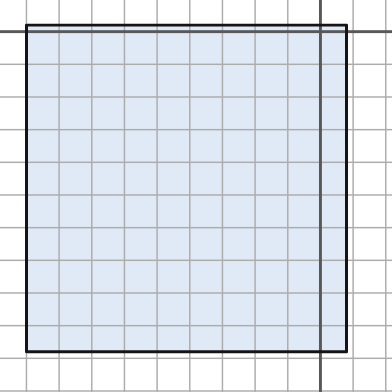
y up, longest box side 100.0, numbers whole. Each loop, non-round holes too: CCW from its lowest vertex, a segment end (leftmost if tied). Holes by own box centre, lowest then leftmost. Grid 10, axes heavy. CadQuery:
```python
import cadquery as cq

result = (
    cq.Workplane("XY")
    .moveTo(-90.0, -98.0)
    .lineTo(8.0, -98.0)
    .lineTo(8.0, 2.0)
    .lineTo(-90.0, 2.0)
    .close()
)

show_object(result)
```